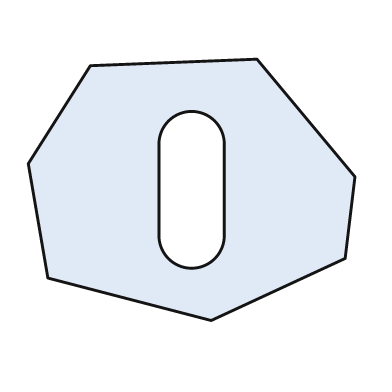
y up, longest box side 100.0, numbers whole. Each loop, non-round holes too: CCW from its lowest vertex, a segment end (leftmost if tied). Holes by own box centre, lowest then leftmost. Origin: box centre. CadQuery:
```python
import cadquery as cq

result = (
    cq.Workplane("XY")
    .moveTo(6.0, -40.0)
    .lineTo(47.0, -21.0)
    .lineTo(50.0, 4.0)
    .lineTo(20.0, 40.0)
    .lineTo(-31.0, 38.0)
    .lineTo(-50.0, 8.0)
    .lineTo(-44.0, -27.0)
    .close()
    .moveTo(-10.0, -14.0)
    .threePointArc((0.0, -24.0), (10.0, -14.0))
    .lineTo(10.0, 14.0)
    .threePointArc((0.0, 24.0), (-10.0, 14.0))
    .close()
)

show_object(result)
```